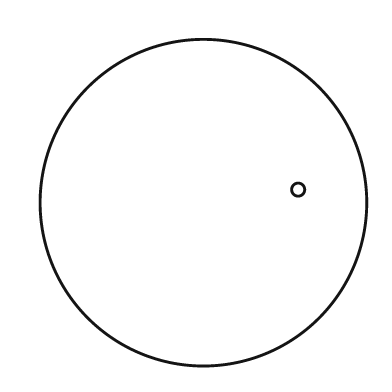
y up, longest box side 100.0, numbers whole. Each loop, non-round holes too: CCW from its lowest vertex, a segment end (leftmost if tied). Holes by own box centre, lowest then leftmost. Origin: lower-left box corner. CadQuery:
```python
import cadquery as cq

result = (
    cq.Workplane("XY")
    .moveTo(50.0, 50.0)
    .circle(50.0)
    .moveTo(79.0, 54.0)
    .circle(2.0)
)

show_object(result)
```